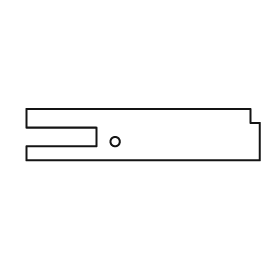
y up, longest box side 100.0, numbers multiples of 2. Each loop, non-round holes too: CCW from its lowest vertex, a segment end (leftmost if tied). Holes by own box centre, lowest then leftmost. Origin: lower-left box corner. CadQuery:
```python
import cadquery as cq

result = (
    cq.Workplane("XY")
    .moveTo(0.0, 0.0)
    .lineTo(100.0, 0.0)
    .lineTo(100.0, 16.0)
    .lineTo(96.0, 16.0)
    .lineTo(96.0, 22.0)
    .lineTo(0.0, 22.0)
    .lineTo(0.0, 14.0)
    .lineTo(30.0, 14.0)
    .lineTo(30.0, 6.0)
    .lineTo(0.0, 6.0)
    .close()
    .moveTo(38.0, 8.0)
    .circle(2.0)
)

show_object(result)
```